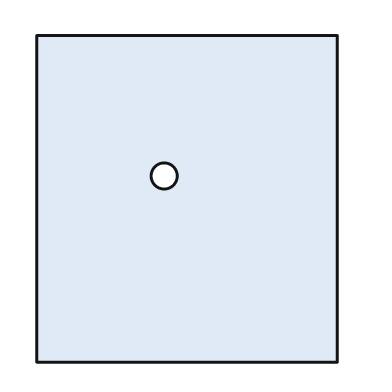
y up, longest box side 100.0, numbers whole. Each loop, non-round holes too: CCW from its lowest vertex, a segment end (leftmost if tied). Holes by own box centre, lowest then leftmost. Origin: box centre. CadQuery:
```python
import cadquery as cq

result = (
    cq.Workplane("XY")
    .moveTo(-46.0, -50.0)
    .lineTo(46.0, -50.0)
    .lineTo(46.0, 50.0)
    .lineTo(-46.0, 50.0)
    .close()
    .moveTo(-7.0, 7.0)
    .circle(4.0)
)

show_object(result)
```